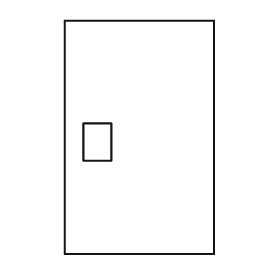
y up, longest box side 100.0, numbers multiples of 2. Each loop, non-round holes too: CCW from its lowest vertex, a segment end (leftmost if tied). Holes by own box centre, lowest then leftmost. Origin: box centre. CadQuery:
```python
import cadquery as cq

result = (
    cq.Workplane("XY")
    .moveTo(-32.0, -50.0)
    .lineTo(32.0, -50.0)
    .lineTo(32.0, 50.0)
    .lineTo(-32.0, 50.0)
    .close()
    .moveTo(-24.0, -10.0)
    .lineTo(-12.0, -10.0)
    .lineTo(-12.0, 6.0)
    .lineTo(-24.0, 6.0)
    .close()
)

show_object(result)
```